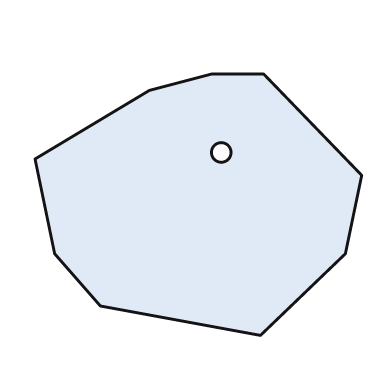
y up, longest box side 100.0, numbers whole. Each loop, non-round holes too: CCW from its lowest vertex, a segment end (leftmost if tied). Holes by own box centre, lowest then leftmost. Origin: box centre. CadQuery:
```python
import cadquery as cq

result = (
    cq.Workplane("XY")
    .moveTo(19.0, -40.0)
    .lineTo(45.0, -15.0)
    .lineTo(50.0, 9.0)
    .lineTo(20.0, 40.0)
    .lineTo(4.0, 40.0)
    .lineTo(-15.0, 35.0)
    .lineTo(-50.0, 14.0)
    .lineTo(-44.0, -15.0)
    .lineTo(-30.0, -31.0)
    .close()
    .moveTo(7.0, 16.0)
    .circle(3.0)
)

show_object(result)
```